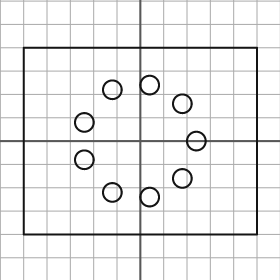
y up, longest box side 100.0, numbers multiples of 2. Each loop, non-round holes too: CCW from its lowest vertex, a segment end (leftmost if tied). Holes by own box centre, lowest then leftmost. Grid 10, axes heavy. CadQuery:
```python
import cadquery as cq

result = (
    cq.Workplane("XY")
    .moveTo(-50.0, -40.0)
    .lineTo(50.0, -40.0)
    .lineTo(50.0, 40.0)
    .lineTo(-50.0, 40.0)
    .close()
    .moveTo(4.0, -24.0)
    .circle(4.0)
    .moveTo(-12.0, -22.0)
    .circle(4.0)
    .moveTo(18.0, -16.0)
    .circle(4.0)
    .moveTo(-24.0, -8.0)
    .circle(4.0)
    .moveTo(24.0, 0.0)
    .circle(4.0)
    .moveTo(-24.0, 8.0)
    .circle(4.0)
    .moveTo(18.0, 16.0)
    .circle(4.0)
    .moveTo(-12.0, 22.0)
    .circle(4.0)
    .moveTo(4.0, 24.0)
    .circle(4.0)
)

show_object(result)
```